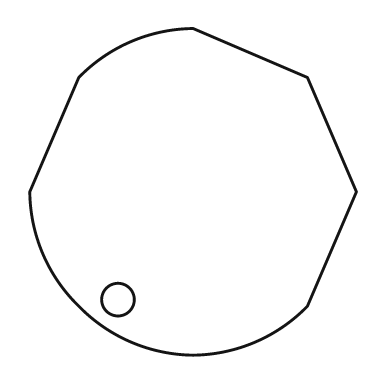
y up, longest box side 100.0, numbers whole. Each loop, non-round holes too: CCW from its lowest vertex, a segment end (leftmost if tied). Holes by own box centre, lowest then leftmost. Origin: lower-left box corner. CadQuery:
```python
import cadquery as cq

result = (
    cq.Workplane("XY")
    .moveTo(50.0, 0.0)
    .threePointArc((69.0, 4.0), (85.0, 15.0))
    .lineTo(100.0, 50.0)
    .lineTo(85.0, 85.0)
    .lineTo(50.0, 100.0)
    .threePointArc((31.0, 96.0), (15.0, 85.0))
    .lineTo(0.0, 50.0)
    .threePointArc((4.0, 31.0), (15.0, 15.0))
    .threePointArc((31.0, 4.0), (50.0, 0.0))
    .close()
    .moveTo(27.0, 17.0)
    .circle(5.0)
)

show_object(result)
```